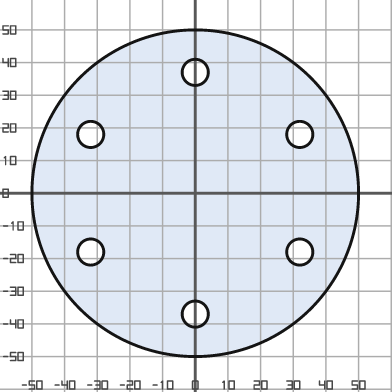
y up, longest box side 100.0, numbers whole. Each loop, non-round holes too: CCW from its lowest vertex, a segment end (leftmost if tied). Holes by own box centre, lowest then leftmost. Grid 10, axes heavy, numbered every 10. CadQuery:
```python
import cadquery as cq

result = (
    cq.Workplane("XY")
    .moveTo(0.0, 0.0)
    .circle(50.0)
    .moveTo(0.0, -37.0)
    .circle(4.0)
    .moveTo(-32.0, -18.0)
    .circle(4.0)
    .moveTo(32.0, -18.0)
    .circle(4.0)
    .moveTo(-32.0, 18.0)
    .circle(4.0)
    .moveTo(32.0, 18.0)
    .circle(4.0)
    .moveTo(0.0, 37.0)
    .circle(4.0)
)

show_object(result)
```